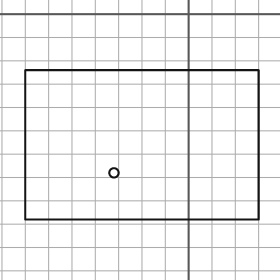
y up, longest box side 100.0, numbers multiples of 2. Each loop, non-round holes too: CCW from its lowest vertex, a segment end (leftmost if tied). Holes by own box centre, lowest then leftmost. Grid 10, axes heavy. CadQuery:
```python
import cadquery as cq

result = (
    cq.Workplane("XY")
    .moveTo(-70.0, -88.0)
    .lineTo(30.0, -88.0)
    .lineTo(30.0, -24.0)
    .lineTo(-70.0, -24.0)
    .close()
    .moveTo(-32.0, -68.0)
    .circle(2.0)
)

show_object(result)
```